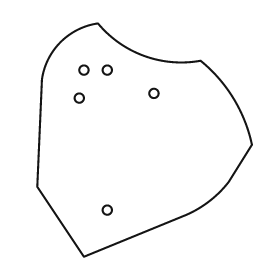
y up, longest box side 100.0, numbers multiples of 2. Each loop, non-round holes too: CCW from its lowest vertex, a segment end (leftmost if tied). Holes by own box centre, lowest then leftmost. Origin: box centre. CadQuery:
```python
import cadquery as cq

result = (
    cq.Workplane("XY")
    .moveTo(-26.0, -50.0)
    .lineTo(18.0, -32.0)
    .threePointArc((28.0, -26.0), (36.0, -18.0))
    .lineTo(46.0, -2.0)
    .threePointArc((38.0, 18.0), (24.0, 34.0))
    .threePointArc((0.0, 36.0), (-20.0, 50.0))
    .threePointArc((-36.0, 42.0), (-44.0, 26.0))
    .lineTo(-46.0, -20.0)
    .close()
    .moveTo(-16.0, -30.0)
    .circle(2.0)
    .moveTo(-28.0, 18.0)
    .circle(2.0)
    .moveTo(4.0, 20.0)
    .circle(2.0)
    .moveTo(-26.0, 30.0)
    .circle(2.0)
    .moveTo(-16.0, 30.0)
    .circle(2.0)
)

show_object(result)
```